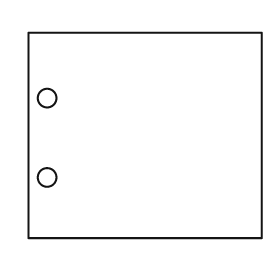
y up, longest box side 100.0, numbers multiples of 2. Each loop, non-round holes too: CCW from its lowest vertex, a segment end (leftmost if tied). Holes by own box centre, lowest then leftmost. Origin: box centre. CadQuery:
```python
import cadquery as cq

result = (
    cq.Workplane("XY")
    .moveTo(-50.0, -44.0)
    .lineTo(50.0, -44.0)
    .lineTo(50.0, 44.0)
    .lineTo(-50.0, 44.0)
    .close()
    .moveTo(-42.0, -18.0)
    .circle(4.0)
    .moveTo(-42.0, 16.0)
    .circle(4.0)
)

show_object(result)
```